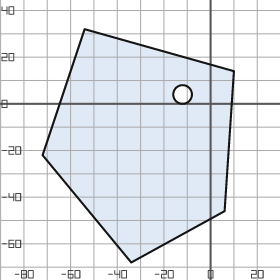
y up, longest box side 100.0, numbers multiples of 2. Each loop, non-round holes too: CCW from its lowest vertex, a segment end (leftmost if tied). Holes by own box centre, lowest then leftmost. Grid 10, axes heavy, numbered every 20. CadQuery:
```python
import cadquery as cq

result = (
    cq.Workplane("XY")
    .moveTo(-34.0, -68.0)
    .lineTo(6.0, -46.0)
    .lineTo(10.0, 14.0)
    .lineTo(-54.0, 32.0)
    .lineTo(-72.0, -22.0)
    .close()
    .moveTo(-12.0, 4.0)
    .circle(4.0)
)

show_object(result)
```